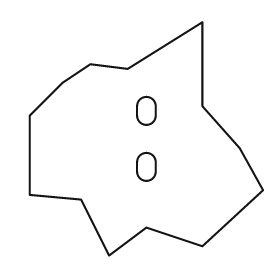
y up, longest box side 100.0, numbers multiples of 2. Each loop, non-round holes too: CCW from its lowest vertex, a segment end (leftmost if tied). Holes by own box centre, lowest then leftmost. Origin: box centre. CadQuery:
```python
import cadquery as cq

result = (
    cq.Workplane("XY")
    .moveTo(-16.0, -50.0)
    .lineTo(0.0, -38.0)
    .lineTo(24.0, -46.0)
    .lineTo(50.0, -22.0)
    .lineTo(40.0, -4.0)
    .lineTo(24.0, 14.0)
    .lineTo(24.0, 50.0)
    .lineTo(-8.0, 30.0)
    .lineTo(-24.0, 32.0)
    .lineTo(-36.0, 24.0)
    .lineTo(-50.0, 10.0)
    .lineTo(-50.0, -24.0)
    .lineTo(-28.0, -26.0)
    .close()
    .moveTo(-4.0, -14.0)
    .threePointArc((0.0, -18.0), (4.0, -14.0))
    .lineTo(4.0, -10.0)
    .threePointArc((0.0, -6.0), (-4.0, -10.0))
    .close()
    .moveTo(-4.0, 10.0)
    .threePointArc((0.0, 6.0), (4.0, 10.0))
    .lineTo(4.0, 14.0)
    .threePointArc((0.0, 18.0), (-4.0, 14.0))
    .close()
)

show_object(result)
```